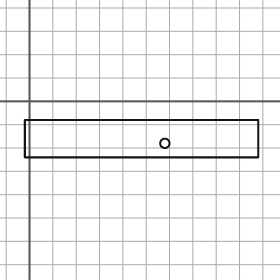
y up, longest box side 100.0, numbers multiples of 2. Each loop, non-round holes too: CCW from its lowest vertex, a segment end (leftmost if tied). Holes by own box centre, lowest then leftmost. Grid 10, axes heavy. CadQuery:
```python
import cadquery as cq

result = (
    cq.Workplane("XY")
    .moveTo(-2.0, -24.0)
    .lineTo(98.0, -24.0)
    .lineTo(98.0, -8.0)
    .lineTo(-2.0, -8.0)
    .close()
    .moveTo(58.0, -18.0)
    .circle(2.0)
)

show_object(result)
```